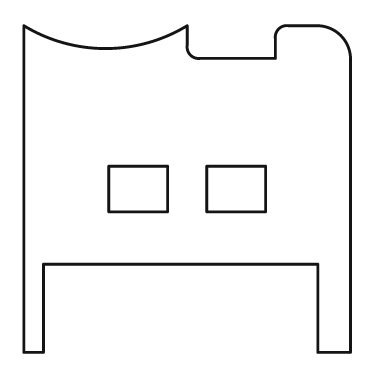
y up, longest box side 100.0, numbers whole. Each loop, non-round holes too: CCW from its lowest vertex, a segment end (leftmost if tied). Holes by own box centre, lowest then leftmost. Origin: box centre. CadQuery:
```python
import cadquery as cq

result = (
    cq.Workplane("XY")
    .moveTo(-50.0, -50.0)
    .lineTo(-44.0, -50.0)
    .lineTo(-44.0, -23.0)
    .lineTo(40.0, -23.0)
    .lineTo(40.0, -50.0)
    .lineTo(50.0, -50.0)
    .lineTo(50.0, 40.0)
    .threePointArc((47.0, 47.0), (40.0, 50.0))
    .lineTo(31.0, 50.0)
    .threePointArc((28.0, 49.0), (27.0, 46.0))
    .lineTo(27.0, 40.0)
    .lineTo(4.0, 40.0)
    .threePointArc((1.0, 41.0), (0.0, 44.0))
    .lineTo(0.0, 50.0)
    .threePointArc((-25.0, 43.0), (-50.0, 50.0))
    .close()
    .moveTo(-24.0, -7.0)
    .lineTo(-6.0, -7.0)
    .lineTo(-6.0, 7.0)
    .lineTo(-24.0, 7.0)
    .close()
    .moveTo(6.0, -7.0)
    .lineTo(24.0, -7.0)
    .lineTo(24.0, 7.0)
    .lineTo(6.0, 7.0)
    .close()
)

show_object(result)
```